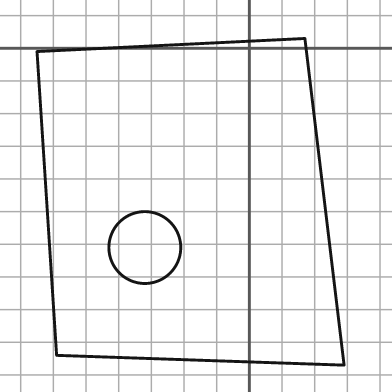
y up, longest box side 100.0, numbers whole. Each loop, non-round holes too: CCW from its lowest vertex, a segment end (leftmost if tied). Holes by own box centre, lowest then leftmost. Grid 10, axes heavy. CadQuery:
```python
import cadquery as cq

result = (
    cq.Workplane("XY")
    .moveTo(29.0, -97.0)
    .lineTo(17.0, 3.0)
    .lineTo(-65.0, -1.0)
    .lineTo(-59.0, -94.0)
    .close()
    .moveTo(-32.0, -61.0)
    .circle(11.0)
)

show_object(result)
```